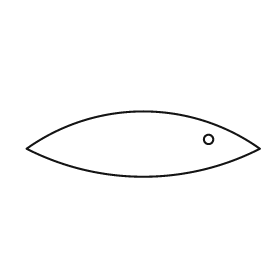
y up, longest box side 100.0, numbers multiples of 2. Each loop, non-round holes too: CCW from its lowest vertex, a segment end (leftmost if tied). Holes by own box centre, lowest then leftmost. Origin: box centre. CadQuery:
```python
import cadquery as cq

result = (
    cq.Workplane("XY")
    .moveTo(-50.0, -2.0)
    .threePointArc((0.0, -14.0), (50.0, -2.0))
    .threePointArc((0.0, 14.0), (-50.0, -2.0))
    .close()
    .moveTo(28.0, 2.0)
    .circle(2.0)
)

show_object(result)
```